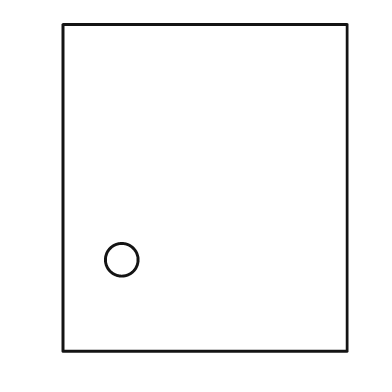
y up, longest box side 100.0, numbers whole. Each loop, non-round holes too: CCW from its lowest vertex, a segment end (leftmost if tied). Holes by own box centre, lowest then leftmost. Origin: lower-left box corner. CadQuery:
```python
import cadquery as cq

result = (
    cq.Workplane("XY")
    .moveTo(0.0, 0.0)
    .lineTo(87.0, 0.0)
    .lineTo(87.0, 100.0)
    .lineTo(0.0, 100.0)
    .close()
    .moveTo(18.0, 28.0)
    .circle(5.0)
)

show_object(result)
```